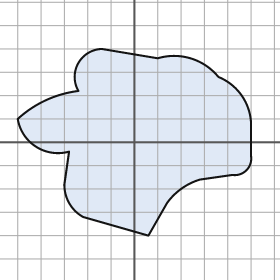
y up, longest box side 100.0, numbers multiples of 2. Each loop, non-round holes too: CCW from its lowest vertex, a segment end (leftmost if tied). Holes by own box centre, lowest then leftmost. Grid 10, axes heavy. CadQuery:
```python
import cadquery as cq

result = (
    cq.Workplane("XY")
    .moveTo(6.0, -40.0)
    .lineTo(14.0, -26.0)
    .threePointArc((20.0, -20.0), (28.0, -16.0))
    .lineTo(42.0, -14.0)
    .threePointArc((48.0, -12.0), (50.0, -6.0))
    .lineTo(50.0, 8.0)
    .threePointArc((46.0, 20.0), (36.0, 28.0))
    .threePointArc((24.0, 36.0), (10.0, 36.0))
    .lineTo(-14.0, 40.0)
    .threePointArc((-24.0, 34.0), (-24.0, 22.0))
    .threePointArc((-38.0, 18.0), (-50.0, 10.0))
    .threePointArc((-42.0, -2.0), (-28.0, -4.0))
    .lineTo(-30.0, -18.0)
    .threePointArc((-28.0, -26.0), (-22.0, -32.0))
    .close()
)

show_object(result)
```